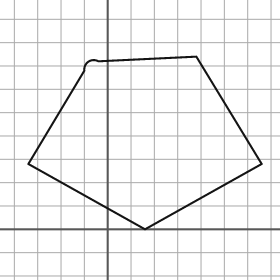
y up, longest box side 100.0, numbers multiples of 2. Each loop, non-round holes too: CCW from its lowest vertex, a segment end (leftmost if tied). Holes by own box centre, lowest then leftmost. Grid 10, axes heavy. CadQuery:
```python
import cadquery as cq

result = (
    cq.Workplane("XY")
    .moveTo(16.0, 0.0)
    .lineTo(66.0, 28.0)
    .lineTo(38.0, 74.0)
    .lineTo(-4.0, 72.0)
    .threePointArc((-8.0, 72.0), (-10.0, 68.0))
    .lineTo(-34.0, 28.0)
    .close()
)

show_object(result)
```